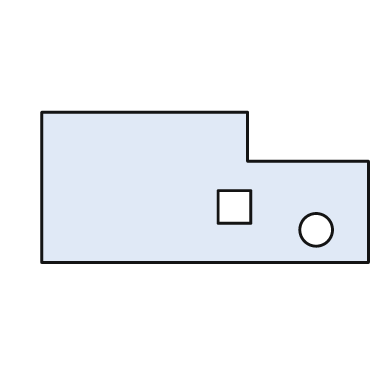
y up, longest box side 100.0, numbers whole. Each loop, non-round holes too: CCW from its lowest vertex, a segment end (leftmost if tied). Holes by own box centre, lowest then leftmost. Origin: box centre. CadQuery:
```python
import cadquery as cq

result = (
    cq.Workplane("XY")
    .moveTo(-50.0, -23.0)
    .lineTo(50.0, -23.0)
    .lineTo(50.0, 8.0)
    .lineTo(13.0, 8.0)
    .lineTo(13.0, 23.0)
    .lineTo(-50.0, 23.0)
    .close()
    .moveTo(34.0, -13.0)
    .circle(5.0)
    .moveTo(4.0, -11.0)
    .lineTo(14.0, -11.0)
    .lineTo(14.0, -1.0)
    .lineTo(4.0, -1.0)
    .close()
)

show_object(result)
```